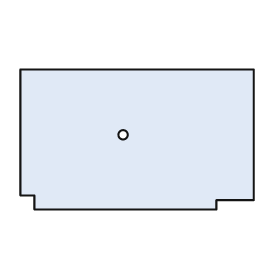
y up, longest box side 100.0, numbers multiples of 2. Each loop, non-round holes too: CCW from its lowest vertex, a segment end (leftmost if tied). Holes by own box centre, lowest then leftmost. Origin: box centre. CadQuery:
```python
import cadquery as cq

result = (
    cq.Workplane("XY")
    .moveTo(-44.0, -30.0)
    .lineTo(34.0, -30.0)
    .lineTo(34.0, -26.0)
    .lineTo(50.0, -26.0)
    .lineTo(50.0, 30.0)
    .lineTo(-50.0, 30.0)
    .lineTo(-50.0, -24.0)
    .lineTo(-44.0, -24.0)
    .close()
    .moveTo(-6.0, 2.0)
    .circle(2.0)
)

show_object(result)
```